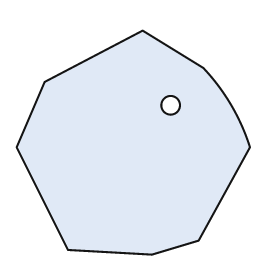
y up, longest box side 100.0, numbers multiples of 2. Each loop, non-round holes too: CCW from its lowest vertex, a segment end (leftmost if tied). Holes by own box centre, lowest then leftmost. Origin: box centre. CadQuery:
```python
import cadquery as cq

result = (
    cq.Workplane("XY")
    .moveTo(8.0, -48.0)
    .lineTo(28.0, -42.0)
    .lineTo(50.0, -2.0)
    .threePointArc((42.0, 16.0), (30.0, 32.0))
    .lineTo(4.0, 48.0)
    .lineTo(-38.0, 26.0)
    .lineTo(-50.0, -2.0)
    .lineTo(-28.0, -46.0)
    .close()
    .moveTo(16.0, 16.0)
    .circle(4.0)
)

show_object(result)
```